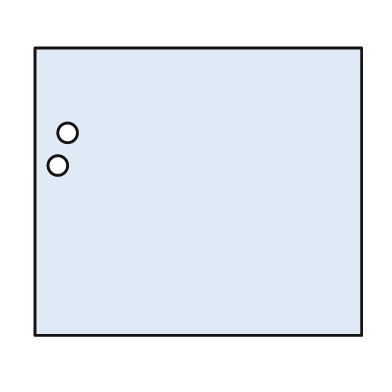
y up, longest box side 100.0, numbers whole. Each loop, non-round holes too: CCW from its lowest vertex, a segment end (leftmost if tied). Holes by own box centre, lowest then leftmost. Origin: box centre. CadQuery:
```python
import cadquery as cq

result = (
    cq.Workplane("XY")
    .moveTo(-50.0, -44.0)
    .lineTo(50.0, -44.0)
    .lineTo(50.0, 44.0)
    .lineTo(-50.0, 44.0)
    .close()
    .moveTo(-43.0, 8.0)
    .circle(3.0)
    .moveTo(-40.0, 18.0)
    .circle(3.0)
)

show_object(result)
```